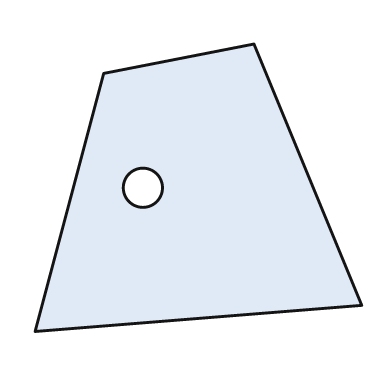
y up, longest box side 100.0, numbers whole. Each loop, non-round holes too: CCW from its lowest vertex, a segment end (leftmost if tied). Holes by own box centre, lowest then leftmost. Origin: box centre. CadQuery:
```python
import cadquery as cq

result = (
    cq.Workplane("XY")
    .moveTo(-50.0, -44.0)
    .lineTo(50.0, -36.0)
    .lineTo(17.0, 44.0)
    .lineTo(-29.0, 35.0)
    .close()
    .moveTo(-17.0, 0.0)
    .circle(6.0)
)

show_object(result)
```